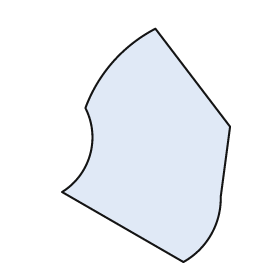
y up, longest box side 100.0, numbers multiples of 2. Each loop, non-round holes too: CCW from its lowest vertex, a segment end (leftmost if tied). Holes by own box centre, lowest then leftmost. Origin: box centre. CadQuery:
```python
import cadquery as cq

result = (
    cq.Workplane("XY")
    .moveTo(16.0, -50.0)
    .threePointArc((28.0, -38.0), (32.0, -22.0))
    .lineTo(36.0, 8.0)
    .lineTo(4.0, 50.0)
    .threePointArc((-14.0, 36.0), (-26.0, 16.0))
    .threePointArc((-24.0, -4.0), (-36.0, -20.0))
    .close()
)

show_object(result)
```